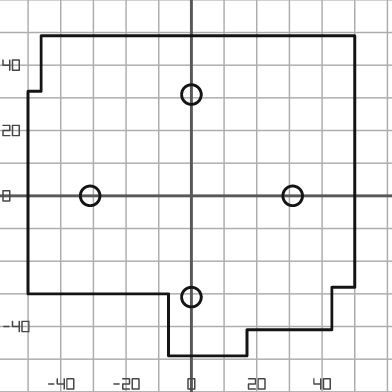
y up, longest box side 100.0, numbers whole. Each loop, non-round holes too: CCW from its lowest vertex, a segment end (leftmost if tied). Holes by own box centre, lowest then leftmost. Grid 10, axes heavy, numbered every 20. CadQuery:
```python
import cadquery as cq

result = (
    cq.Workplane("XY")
    .moveTo(-7.0, -49.0)
    .lineTo(17.0, -49.0)
    .lineTo(17.0, -41.0)
    .lineTo(43.0, -41.0)
    .lineTo(43.0, -28.0)
    .lineTo(50.0, -28.0)
    .lineTo(50.0, 49.0)
    .lineTo(-46.0, 49.0)
    .lineTo(-46.0, 32.0)
    .lineTo(-50.0, 32.0)
    .lineTo(-50.0, -30.0)
    .lineTo(-7.0, -30.0)
    .close()
    .moveTo(0.0, -31.0)
    .circle(3.0)
    .moveTo(-31.0, 0.0)
    .circle(3.0)
    .moveTo(31.0, 0.0)
    .circle(3.0)
    .moveTo(0.0, 31.0)
    .circle(3.0)
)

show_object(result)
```